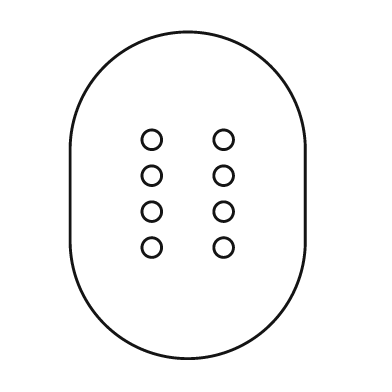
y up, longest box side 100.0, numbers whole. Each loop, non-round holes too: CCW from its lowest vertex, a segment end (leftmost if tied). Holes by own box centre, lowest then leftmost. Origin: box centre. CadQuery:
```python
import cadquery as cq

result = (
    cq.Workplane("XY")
    .moveTo(-36.0, -14.0)
    .threePointArc((0.0, -50.0), (36.0, -14.0))
    .lineTo(36.0, 14.0)
    .threePointArc((0.0, 50.0), (-36.0, 14.0))
    .close()
    .moveTo(-11.0, -16.0)
    .circle(3.0)
    .moveTo(11.0, -16.0)
    .circle(3.0)
    .moveTo(-11.0, -5.0)
    .circle(3.0)
    .moveTo(11.0, -5.0)
    .circle(3.0)
    .moveTo(-11.0, 6.0)
    .circle(3.0)
    .moveTo(11.0, 6.0)
    .circle(3.0)
    .moveTo(-11.0, 17.0)
    .circle(3.0)
    .moveTo(11.0, 17.0)
    .circle(3.0)
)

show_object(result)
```